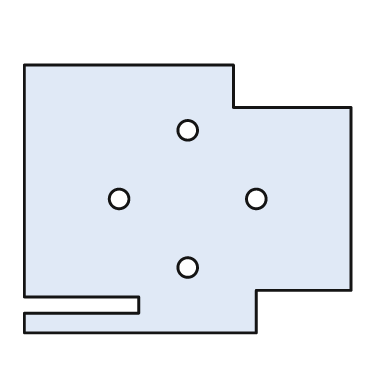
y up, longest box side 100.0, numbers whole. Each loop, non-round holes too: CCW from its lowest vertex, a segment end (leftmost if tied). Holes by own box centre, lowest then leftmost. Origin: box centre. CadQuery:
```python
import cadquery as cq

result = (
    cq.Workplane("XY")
    .moveTo(-50.0, -41.0)
    .lineTo(21.0, -41.0)
    .lineTo(21.0, -28.0)
    .lineTo(50.0, -28.0)
    .lineTo(50.0, 28.0)
    .lineTo(14.0, 28.0)
    .lineTo(14.0, 41.0)
    .lineTo(-50.0, 41.0)
    .lineTo(-50.0, -30.0)
    .lineTo(-15.0, -30.0)
    .lineTo(-15.0, -35.0)
    .lineTo(-50.0, -35.0)
    .close()
    .moveTo(0.0, -21.0)
    .circle(3.0)
    .moveTo(-21.0, 0.0)
    .circle(3.0)
    .moveTo(21.0, 0.0)
    .circle(3.0)
    .moveTo(0.0, 21.0)
    .circle(3.0)
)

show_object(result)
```